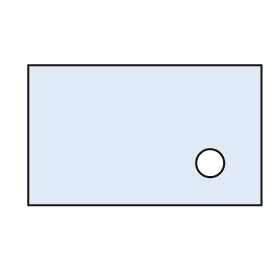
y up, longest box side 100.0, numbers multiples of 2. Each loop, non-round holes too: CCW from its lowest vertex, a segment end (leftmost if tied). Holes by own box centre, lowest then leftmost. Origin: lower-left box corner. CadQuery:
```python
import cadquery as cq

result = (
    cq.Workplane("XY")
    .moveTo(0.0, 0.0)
    .lineTo(100.0, 0.0)
    .lineTo(100.0, 60.0)
    .lineTo(0.0, 60.0)
    .close()
    .moveTo(78.0, 18.0)
    .circle(6.0)
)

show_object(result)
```